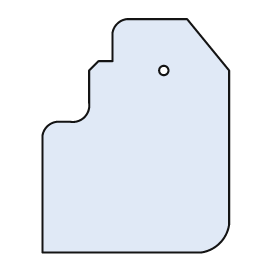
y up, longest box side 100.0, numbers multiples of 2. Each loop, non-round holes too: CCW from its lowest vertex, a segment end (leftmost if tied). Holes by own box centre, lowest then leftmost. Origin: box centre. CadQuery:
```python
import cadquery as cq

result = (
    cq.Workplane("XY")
    .moveTo(-40.0, -50.0)
    .lineTo(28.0, -50.0)
    .threePointArc((36.0, -46.0), (40.0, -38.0))
    .lineTo(40.0, 28.0)
    .lineTo(22.0, 50.0)
    .lineTo(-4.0, 50.0)
    .threePointArc((-8.0, 48.0), (-10.0, 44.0))
    .lineTo(-10.0, 32.0)
    .lineTo(-16.0, 32.0)
    .lineTo(-20.0, 28.0)
    .lineTo(-20.0, 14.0)
    .threePointArc((-22.0, 8.0), (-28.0, 6.0))
    .lineTo(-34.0, 6.0)
    .threePointArc((-38.0, 4.0), (-40.0, 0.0))
    .close()
    .moveTo(12.0, 28.0)
    .circle(2.0)
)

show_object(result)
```